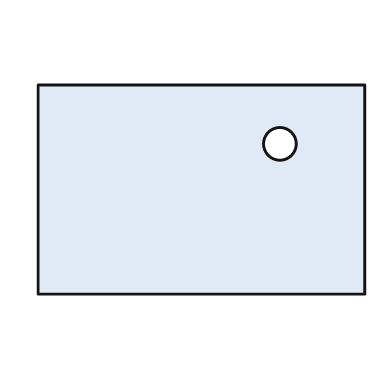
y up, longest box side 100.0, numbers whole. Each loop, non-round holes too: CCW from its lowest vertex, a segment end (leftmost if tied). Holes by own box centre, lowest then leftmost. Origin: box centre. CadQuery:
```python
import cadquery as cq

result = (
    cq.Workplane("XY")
    .moveTo(-50.0, -32.0)
    .lineTo(50.0, -32.0)
    .lineTo(50.0, 32.0)
    .lineTo(-50.0, 32.0)
    .close()
    .moveTo(24.0, 14.0)
    .circle(5.0)
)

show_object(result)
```